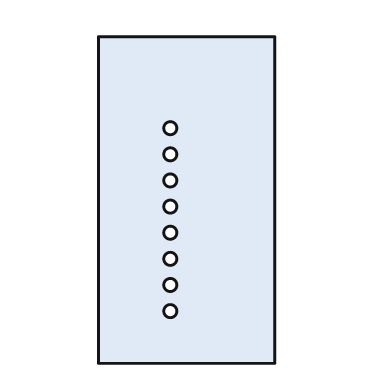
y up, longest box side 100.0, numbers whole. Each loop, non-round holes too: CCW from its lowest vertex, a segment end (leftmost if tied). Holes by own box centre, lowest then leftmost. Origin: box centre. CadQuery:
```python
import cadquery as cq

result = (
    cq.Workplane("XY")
    .moveTo(-27.0, -50.0)
    .lineTo(27.0, -50.0)
    .lineTo(27.0, 50.0)
    .lineTo(-27.0, 50.0)
    .close()
    .moveTo(-5.0, -34.0)
    .circle(2.0)
    .moveTo(-5.0, -26.0)
    .circle(2.0)
    .moveTo(-5.0, -18.0)
    .circle(2.0)
    .moveTo(-5.0, -10.0)
    .circle(2.0)
    .moveTo(-5.0, -2.0)
    .circle(2.0)
    .moveTo(-5.0, 6.0)
    .circle(2.0)
    .moveTo(-5.0, 14.0)
    .circle(2.0)
    .moveTo(-5.0, 22.0)
    .circle(2.0)
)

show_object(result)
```